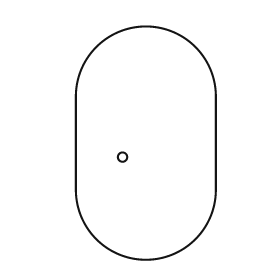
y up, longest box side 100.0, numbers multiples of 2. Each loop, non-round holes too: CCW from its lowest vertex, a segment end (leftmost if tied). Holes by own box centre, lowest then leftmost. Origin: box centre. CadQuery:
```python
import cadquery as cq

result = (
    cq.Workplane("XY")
    .moveTo(-30.0, -20.0)
    .threePointArc((0.0, -50.0), (30.0, -20.0))
    .lineTo(30.0, 20.0)
    .threePointArc((0.0, 50.0), (-30.0, 20.0))
    .close()
    .moveTo(-10.0, -6.0)
    .circle(2.0)
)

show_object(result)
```